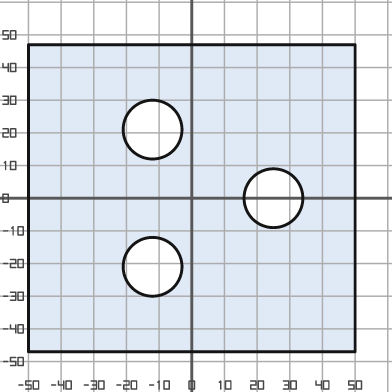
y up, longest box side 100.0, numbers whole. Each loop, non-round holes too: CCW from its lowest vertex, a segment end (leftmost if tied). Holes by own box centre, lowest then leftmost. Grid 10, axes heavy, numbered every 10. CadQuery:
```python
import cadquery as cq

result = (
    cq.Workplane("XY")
    .moveTo(-50.0, -47.0)
    .lineTo(50.0, -47.0)
    .lineTo(50.0, 47.0)
    .lineTo(-50.0, 47.0)
    .close()
    .moveTo(-12.0, -21.0)
    .circle(9.0)
    .moveTo(25.0, 0.0)
    .circle(9.0)
    .moveTo(-12.0, 21.0)
    .circle(9.0)
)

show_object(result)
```